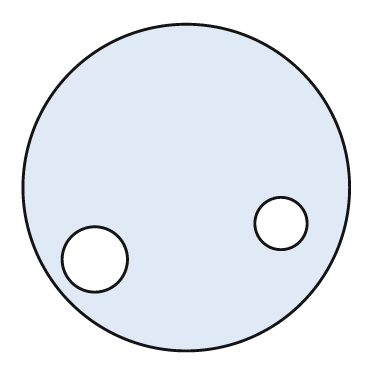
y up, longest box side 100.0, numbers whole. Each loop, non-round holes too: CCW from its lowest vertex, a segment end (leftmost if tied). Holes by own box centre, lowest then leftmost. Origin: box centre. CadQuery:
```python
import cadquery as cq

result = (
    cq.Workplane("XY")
    .moveTo(0.0, 0.0)
    .circle(50.0)
    .moveTo(-28.0, -22.0)
    .circle(10.0)
    .moveTo(29.0, -11.0)
    .circle(8.0)
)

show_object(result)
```